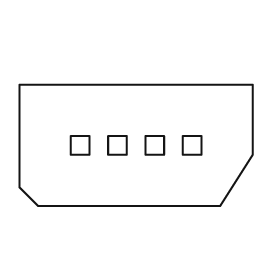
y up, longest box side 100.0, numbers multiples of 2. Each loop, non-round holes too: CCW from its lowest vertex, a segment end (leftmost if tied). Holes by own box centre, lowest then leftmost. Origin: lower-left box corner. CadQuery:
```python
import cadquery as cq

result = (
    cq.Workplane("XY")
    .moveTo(8.0, 0.0)
    .lineTo(86.0, 0.0)
    .lineTo(100.0, 22.0)
    .lineTo(100.0, 52.0)
    .lineTo(0.0, 52.0)
    .lineTo(0.0, 8.0)
    .close()
    .moveTo(22.0, 22.0)
    .lineTo(30.0, 22.0)
    .lineTo(30.0, 30.0)
    .lineTo(22.0, 30.0)
    .close()
    .moveTo(38.0, 22.0)
    .lineTo(46.0, 22.0)
    .lineTo(46.0, 30.0)
    .lineTo(38.0, 30.0)
    .close()
    .moveTo(54.0, 22.0)
    .lineTo(62.0, 22.0)
    .lineTo(62.0, 30.0)
    .lineTo(54.0, 30.0)
    .close()
    .moveTo(70.0, 22.0)
    .lineTo(78.0, 22.0)
    .lineTo(78.0, 30.0)
    .lineTo(70.0, 30.0)
    .close()
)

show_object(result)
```